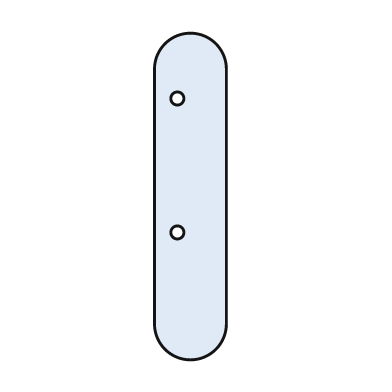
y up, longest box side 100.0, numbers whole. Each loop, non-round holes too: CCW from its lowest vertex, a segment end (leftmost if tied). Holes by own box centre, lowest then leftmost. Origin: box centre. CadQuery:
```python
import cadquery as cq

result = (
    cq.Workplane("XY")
    .moveTo(-11.0, -39.0)
    .threePointArc((0.0, -50.0), (11.0, -39.0))
    .lineTo(11.0, 39.0)
    .threePointArc((0.0, 50.0), (-11.0, 39.0))
    .close()
    .moveTo(-4.0, -11.0)
    .circle(2.0)
    .moveTo(-4.0, 30.0)
    .circle(2.0)
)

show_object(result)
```